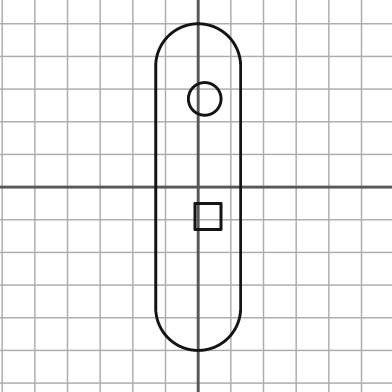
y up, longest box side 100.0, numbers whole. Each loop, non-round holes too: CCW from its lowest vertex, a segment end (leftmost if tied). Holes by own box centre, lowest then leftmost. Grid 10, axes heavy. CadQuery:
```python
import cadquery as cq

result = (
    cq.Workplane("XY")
    .moveTo(-13.0, -37.0)
    .threePointArc((0.0, -50.0), (13.0, -37.0))
    .lineTo(13.0, 37.0)
    .threePointArc((0.0, 50.0), (-13.0, 37.0))
    .close()
    .moveTo(-1.0, -13.0)
    .lineTo(7.0, -13.0)
    .lineTo(7.0, -5.0)
    .lineTo(-1.0, -5.0)
    .close()
    .moveTo(2.0, 27.0)
    .circle(5.0)
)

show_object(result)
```